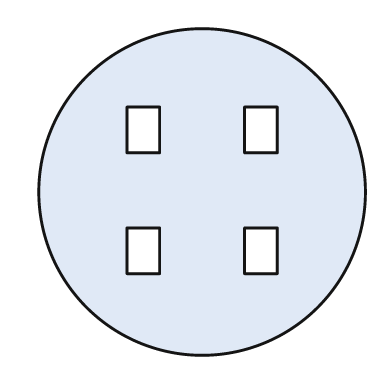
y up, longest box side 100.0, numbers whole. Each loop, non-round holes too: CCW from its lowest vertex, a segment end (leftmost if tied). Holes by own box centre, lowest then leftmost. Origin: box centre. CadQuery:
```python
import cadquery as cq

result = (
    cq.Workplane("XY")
    .moveTo(0.0, 0.0)
    .circle(50.0)
    .moveTo(-23.0, -25.0)
    .lineTo(-13.0, -25.0)
    .lineTo(-13.0, -11.0)
    .lineTo(-23.0, -11.0)
    .close()
    .moveTo(13.0, -25.0)
    .lineTo(23.0, -25.0)
    .lineTo(23.0, -11.0)
    .lineTo(13.0, -11.0)
    .close()
    .moveTo(-23.0, 12.0)
    .lineTo(-13.0, 12.0)
    .lineTo(-13.0, 26.0)
    .lineTo(-23.0, 26.0)
    .close()
    .moveTo(13.0, 12.0)
    .lineTo(23.0, 12.0)
    .lineTo(23.0, 26.0)
    .lineTo(13.0, 26.0)
    .close()
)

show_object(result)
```